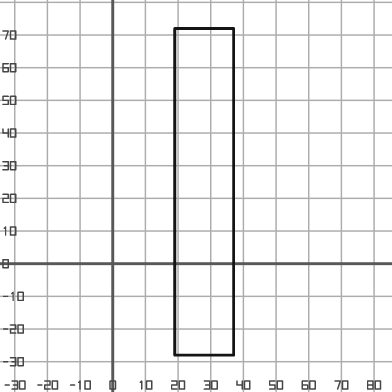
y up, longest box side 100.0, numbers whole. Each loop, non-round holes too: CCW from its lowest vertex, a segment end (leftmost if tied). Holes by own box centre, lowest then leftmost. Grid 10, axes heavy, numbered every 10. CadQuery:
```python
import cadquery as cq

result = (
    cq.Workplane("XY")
    .moveTo(19.0, -28.0)
    .lineTo(37.0, -28.0)
    .lineTo(37.0, 72.0)
    .lineTo(19.0, 72.0)
    .close()
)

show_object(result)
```